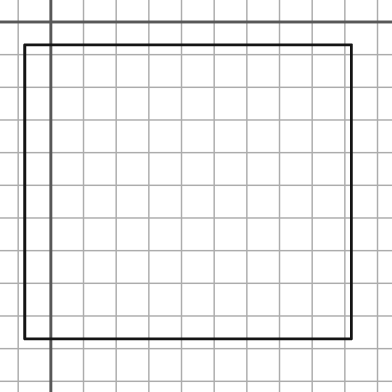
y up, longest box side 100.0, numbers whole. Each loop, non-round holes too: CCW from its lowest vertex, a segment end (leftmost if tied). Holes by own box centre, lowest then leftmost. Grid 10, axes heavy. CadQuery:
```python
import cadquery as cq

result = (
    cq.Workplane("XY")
    .moveTo(-8.0, -97.0)
    .lineTo(92.0, -97.0)
    .lineTo(92.0, -7.0)
    .lineTo(-8.0, -7.0)
    .close()
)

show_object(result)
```